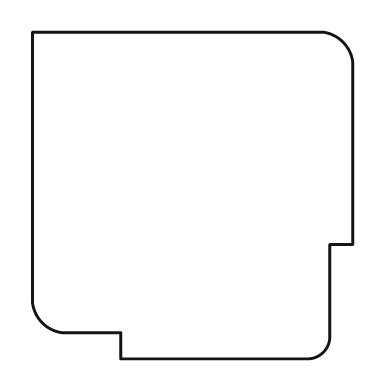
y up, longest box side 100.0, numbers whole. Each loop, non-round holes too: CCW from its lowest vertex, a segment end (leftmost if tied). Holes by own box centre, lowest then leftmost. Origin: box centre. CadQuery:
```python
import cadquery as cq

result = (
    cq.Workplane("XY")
    .moveTo(-22.0, -50.0)
    .lineTo(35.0, -50.0)
    .threePointArc((40.0, -48.0), (42.0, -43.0))
    .lineTo(42.0, -15.0)
    .lineTo(49.0, -15.0)
    .lineTo(49.0, 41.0)
    .threePointArc((46.0, 47.0), (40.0, 50.0))
    .lineTo(-49.0, 50.0)
    .lineTo(-49.0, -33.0)
    .threePointArc((-46.0, -39.0), (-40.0, -42.0))
    .lineTo(-22.0, -42.0)
    .close()
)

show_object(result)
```